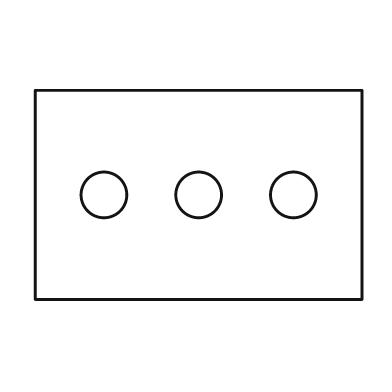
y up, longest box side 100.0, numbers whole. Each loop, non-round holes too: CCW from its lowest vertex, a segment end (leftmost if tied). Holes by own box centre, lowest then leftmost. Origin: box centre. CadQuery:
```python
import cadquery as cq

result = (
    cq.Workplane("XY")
    .moveTo(-50.0, -32.0)
    .lineTo(50.0, -32.0)
    .lineTo(50.0, 32.0)
    .lineTo(-50.0, 32.0)
    .close()
    .moveTo(-29.0, 0.0)
    .circle(7.0)
    .moveTo(0.0, 0.0)
    .circle(7.0)
    .moveTo(29.0, 0.0)
    .circle(7.0)
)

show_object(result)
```